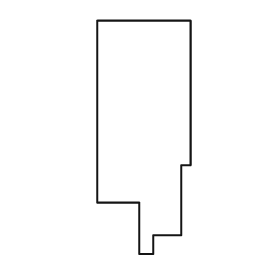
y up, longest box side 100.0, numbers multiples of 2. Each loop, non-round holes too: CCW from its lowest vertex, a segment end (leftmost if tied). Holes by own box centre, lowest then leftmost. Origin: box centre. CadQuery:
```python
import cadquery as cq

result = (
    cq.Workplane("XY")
    .moveTo(-2.0, -50.0)
    .lineTo(4.0, -50.0)
    .lineTo(4.0, -42.0)
    .lineTo(16.0, -42.0)
    .lineTo(16.0, -12.0)
    .lineTo(20.0, -12.0)
    .lineTo(20.0, 50.0)
    .lineTo(-20.0, 50.0)
    .lineTo(-20.0, -28.0)
    .lineTo(-2.0, -28.0)
    .close()
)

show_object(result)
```